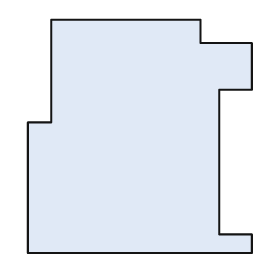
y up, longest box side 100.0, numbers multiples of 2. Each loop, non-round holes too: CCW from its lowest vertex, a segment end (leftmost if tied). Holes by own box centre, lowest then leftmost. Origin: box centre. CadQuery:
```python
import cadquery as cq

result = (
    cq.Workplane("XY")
    .moveTo(-48.0, -50.0)
    .lineTo(48.0, -50.0)
    .lineTo(48.0, -42.0)
    .lineTo(34.0, -42.0)
    .lineTo(34.0, 20.0)
    .lineTo(48.0, 20.0)
    .lineTo(48.0, 40.0)
    .lineTo(26.0, 40.0)
    .lineTo(26.0, 50.0)
    .lineTo(-38.0, 50.0)
    .lineTo(-38.0, 6.0)
    .lineTo(-48.0, 6.0)
    .close()
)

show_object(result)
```